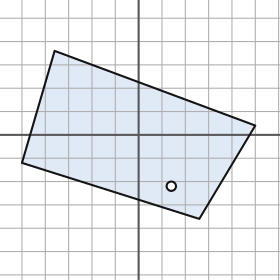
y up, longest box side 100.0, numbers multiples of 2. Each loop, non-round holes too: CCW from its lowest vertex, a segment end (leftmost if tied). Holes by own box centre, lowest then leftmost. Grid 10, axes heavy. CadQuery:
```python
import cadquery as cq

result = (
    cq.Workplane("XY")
    .moveTo(26.0, -36.0)
    .lineTo(50.0, 4.0)
    .lineTo(-36.0, 36.0)
    .lineTo(-50.0, -12.0)
    .close()
    .moveTo(14.0, -22.0)
    .circle(2.0)
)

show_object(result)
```